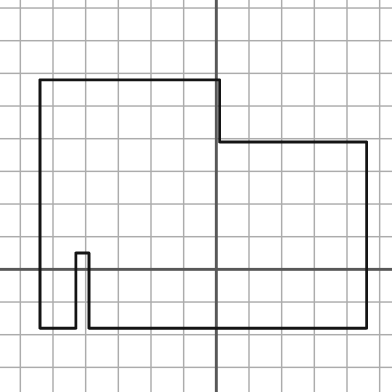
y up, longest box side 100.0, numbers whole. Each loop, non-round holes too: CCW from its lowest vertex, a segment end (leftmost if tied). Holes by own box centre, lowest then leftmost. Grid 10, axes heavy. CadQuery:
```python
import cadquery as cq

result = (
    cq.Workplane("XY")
    .moveTo(-54.0, -18.0)
    .lineTo(-43.0, -18.0)
    .lineTo(-43.0, 5.0)
    .lineTo(-39.0, 5.0)
    .lineTo(-39.0, -18.0)
    .lineTo(46.0, -18.0)
    .lineTo(46.0, 39.0)
    .lineTo(1.0, 39.0)
    .lineTo(1.0, 58.0)
    .lineTo(-54.0, 58.0)
    .close()
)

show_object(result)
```